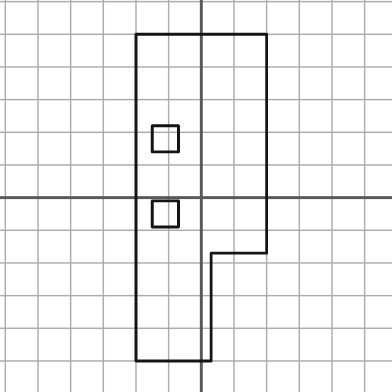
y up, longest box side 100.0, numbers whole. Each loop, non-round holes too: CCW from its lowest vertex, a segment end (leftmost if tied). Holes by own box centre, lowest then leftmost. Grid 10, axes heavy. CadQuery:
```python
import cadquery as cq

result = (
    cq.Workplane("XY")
    .moveTo(-20.0, -50.0)
    .lineTo(3.0, -50.0)
    .lineTo(3.0, -17.0)
    .lineTo(20.0, -17.0)
    .lineTo(20.0, 50.0)
    .lineTo(-20.0, 50.0)
    .close()
    .moveTo(-15.0, -9.0)
    .lineTo(-7.0, -9.0)
    .lineTo(-7.0, -1.0)
    .lineTo(-15.0, -1.0)
    .close()
    .moveTo(-15.0, 14.0)
    .lineTo(-7.0, 14.0)
    .lineTo(-7.0, 22.0)
    .lineTo(-15.0, 22.0)
    .close()
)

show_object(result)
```